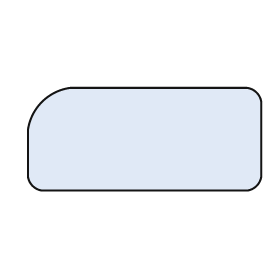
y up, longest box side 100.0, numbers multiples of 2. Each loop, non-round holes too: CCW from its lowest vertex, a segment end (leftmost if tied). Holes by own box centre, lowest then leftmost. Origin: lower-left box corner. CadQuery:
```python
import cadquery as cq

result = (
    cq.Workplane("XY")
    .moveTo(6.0, 0.0)
    .lineTo(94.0, 0.0)
    .threePointArc((98.0, 2.0), (100.0, 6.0))
    .lineTo(100.0, 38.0)
    .threePointArc((98.0, 42.0), (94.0, 44.0))
    .lineTo(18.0, 44.0)
    .threePointArc((6.0, 38.0), (0.0, 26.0))
    .lineTo(0.0, 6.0)
    .threePointArc((2.0, 2.0), (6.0, 0.0))
    .close()
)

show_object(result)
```